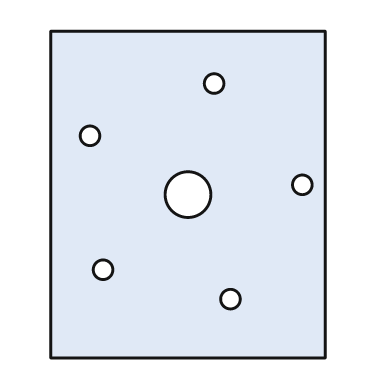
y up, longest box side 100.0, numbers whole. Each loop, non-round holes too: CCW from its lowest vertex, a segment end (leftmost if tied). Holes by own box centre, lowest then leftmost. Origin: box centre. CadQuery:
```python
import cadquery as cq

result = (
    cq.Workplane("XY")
    .moveTo(-42.0, -50.0)
    .lineTo(42.0, -50.0)
    .lineTo(42.0, 50.0)
    .lineTo(-42.0, 50.0)
    .close()
    .moveTo(13.0, -32.0)
    .circle(3.0)
    .moveTo(-26.0, -23.0)
    .circle(3.0)
    .moveTo(0.0, 0.0)
    .circle(7.0)
    .moveTo(35.0, 3.0)
    .circle(3.0)
    .moveTo(-30.0, 18.0)
    .circle(3.0)
    .moveTo(8.0, 34.0)
    .circle(3.0)
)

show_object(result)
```